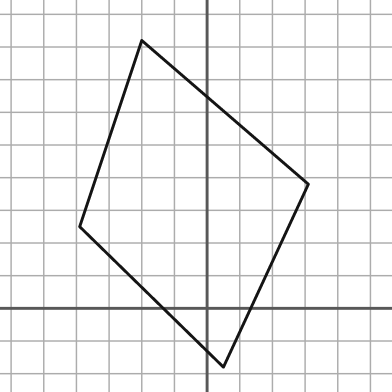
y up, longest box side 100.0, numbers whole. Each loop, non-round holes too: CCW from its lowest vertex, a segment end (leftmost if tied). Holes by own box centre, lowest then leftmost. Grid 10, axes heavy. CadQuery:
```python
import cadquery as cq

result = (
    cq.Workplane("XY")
    .moveTo(5.0, -18.0)
    .lineTo(31.0, 38.0)
    .lineTo(-20.0, 82.0)
    .lineTo(-39.0, 25.0)
    .close()
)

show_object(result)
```